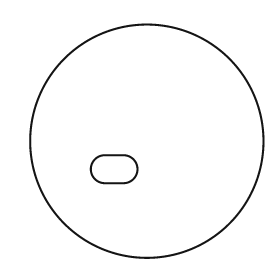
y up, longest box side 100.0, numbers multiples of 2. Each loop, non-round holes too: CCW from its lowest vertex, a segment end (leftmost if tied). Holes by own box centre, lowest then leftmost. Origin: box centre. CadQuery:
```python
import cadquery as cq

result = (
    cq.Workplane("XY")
    .moveTo(0.0, 0.0)
    .circle(50.0)
    .moveTo(-18.0, -18.0)
    .lineTo(-10.0, -18.0)
    .threePointArc((-4.0, -12.0), (-10.0, -6.0))
    .lineTo(-18.0, -6.0)
    .threePointArc((-24.0, -12.0), (-18.0, -18.0))
    .close()
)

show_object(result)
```